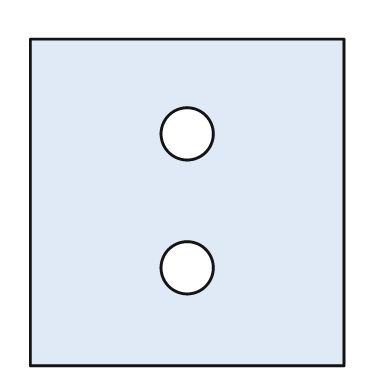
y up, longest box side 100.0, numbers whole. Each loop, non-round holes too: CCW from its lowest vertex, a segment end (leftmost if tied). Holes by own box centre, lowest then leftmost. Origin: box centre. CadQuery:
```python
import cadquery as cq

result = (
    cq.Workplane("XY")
    .moveTo(-48.0, -50.0)
    .lineTo(48.0, -50.0)
    .lineTo(48.0, 50.0)
    .lineTo(-48.0, 50.0)
    .close()
    .moveTo(0.0, -20.0)
    .circle(8.0)
    .moveTo(0.0, 21.0)
    .circle(8.0)
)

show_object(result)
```